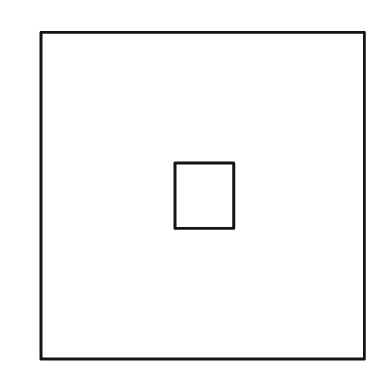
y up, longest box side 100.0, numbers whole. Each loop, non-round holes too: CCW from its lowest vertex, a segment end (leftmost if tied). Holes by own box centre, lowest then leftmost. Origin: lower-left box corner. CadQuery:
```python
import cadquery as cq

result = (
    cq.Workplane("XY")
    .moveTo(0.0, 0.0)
    .lineTo(99.0, 0.0)
    .lineTo(99.0, 100.0)
    .lineTo(0.0, 100.0)
    .close()
    .moveTo(41.0, 40.0)
    .lineTo(59.0, 40.0)
    .lineTo(59.0, 60.0)
    .lineTo(41.0, 60.0)
    .close()
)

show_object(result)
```